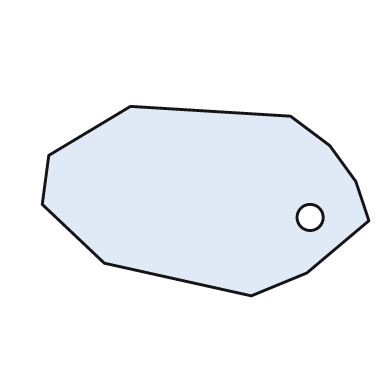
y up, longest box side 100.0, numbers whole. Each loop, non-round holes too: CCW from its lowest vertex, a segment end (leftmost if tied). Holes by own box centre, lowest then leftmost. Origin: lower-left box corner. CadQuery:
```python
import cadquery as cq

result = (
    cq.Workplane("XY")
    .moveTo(64.0, 0.0)
    .lineTo(81.0, 7.0)
    .lineTo(100.0, 23.0)
    .lineTo(96.0, 35.0)
    .lineTo(88.0, 46.0)
    .lineTo(76.0, 55.0)
    .lineTo(27.0, 58.0)
    .lineTo(2.0, 43.0)
    .lineTo(0.0, 28.0)
    .lineTo(19.0, 10.0)
    .close()
    .moveTo(82.0, 24.0)
    .circle(4.0)
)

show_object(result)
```